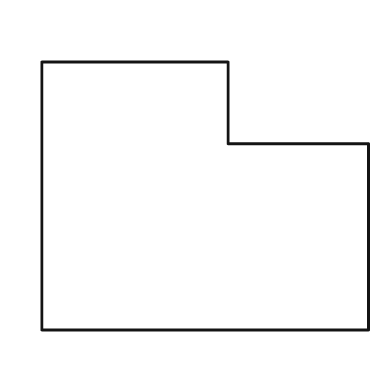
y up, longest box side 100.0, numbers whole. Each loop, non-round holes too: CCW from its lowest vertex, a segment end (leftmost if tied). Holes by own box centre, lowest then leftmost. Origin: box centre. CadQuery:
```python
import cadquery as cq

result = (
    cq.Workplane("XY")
    .moveTo(-50.0, -41.0)
    .lineTo(50.0, -41.0)
    .lineTo(50.0, 16.0)
    .lineTo(7.0, 16.0)
    .lineTo(7.0, 41.0)
    .lineTo(-50.0, 41.0)
    .close()
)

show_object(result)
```